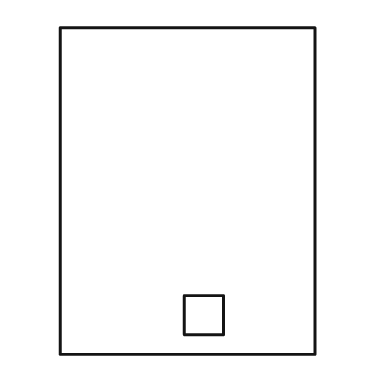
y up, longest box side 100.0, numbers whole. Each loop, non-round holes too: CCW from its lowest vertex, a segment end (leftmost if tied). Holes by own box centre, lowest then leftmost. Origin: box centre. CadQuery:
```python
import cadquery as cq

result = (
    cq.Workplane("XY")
    .moveTo(-39.0, -50.0)
    .lineTo(39.0, -50.0)
    .lineTo(39.0, 50.0)
    .lineTo(-39.0, 50.0)
    .close()
    .moveTo(-1.0, -44.0)
    .lineTo(11.0, -44.0)
    .lineTo(11.0, -32.0)
    .lineTo(-1.0, -32.0)
    .close()
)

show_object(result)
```